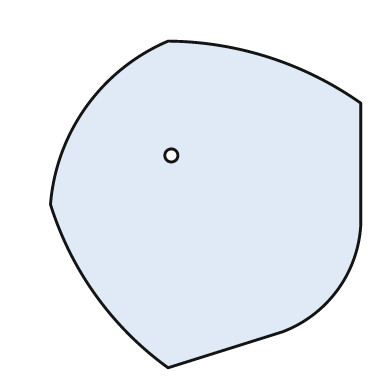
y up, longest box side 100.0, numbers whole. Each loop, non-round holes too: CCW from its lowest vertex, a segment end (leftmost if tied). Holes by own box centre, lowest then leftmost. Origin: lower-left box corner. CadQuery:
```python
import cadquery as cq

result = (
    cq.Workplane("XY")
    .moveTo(36.0, 0.0)
    .lineTo(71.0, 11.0)
    .threePointArc((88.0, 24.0), (95.0, 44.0))
    .lineTo(95.0, 81.0)
    .threePointArc((67.0, 95.0), (36.0, 100.0))
    .threePointArc((11.0, 80.0), (0.0, 50.0))
    .threePointArc((14.0, 22.0), (36.0, 0.0))
    .close()
    .moveTo(37.0, 65.0)
    .circle(2.0)
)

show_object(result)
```